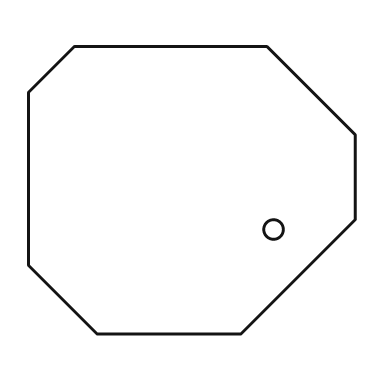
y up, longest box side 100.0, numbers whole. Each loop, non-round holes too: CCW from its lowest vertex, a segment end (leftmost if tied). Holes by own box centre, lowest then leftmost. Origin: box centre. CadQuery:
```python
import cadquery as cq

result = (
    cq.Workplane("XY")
    .moveTo(-29.0, -44.0)
    .lineTo(15.0, -44.0)
    .lineTo(50.0, -9.0)
    .lineTo(50.0, 17.0)
    .lineTo(23.0, 44.0)
    .lineTo(-36.0, 44.0)
    .lineTo(-50.0, 30.0)
    .lineTo(-50.0, -23.0)
    .close()
    .moveTo(25.0, -12.0)
    .circle(3.0)
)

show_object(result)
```